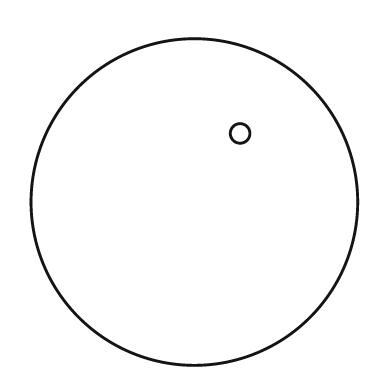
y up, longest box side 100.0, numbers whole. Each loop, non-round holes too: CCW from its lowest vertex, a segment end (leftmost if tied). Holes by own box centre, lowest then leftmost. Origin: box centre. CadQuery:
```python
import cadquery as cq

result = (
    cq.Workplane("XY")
    .moveTo(0.0, 0.0)
    .circle(50.0)
    .moveTo(14.0, 21.0)
    .circle(3.0)
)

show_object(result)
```